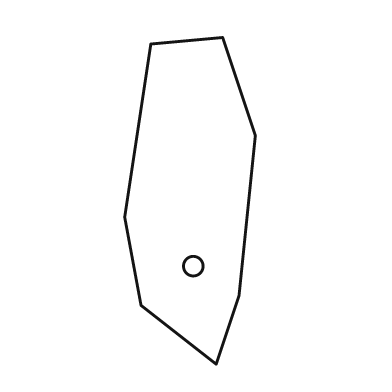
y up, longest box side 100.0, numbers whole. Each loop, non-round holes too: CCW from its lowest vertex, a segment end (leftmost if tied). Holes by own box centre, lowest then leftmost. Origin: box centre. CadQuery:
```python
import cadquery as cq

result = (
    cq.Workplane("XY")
    .moveTo(8.0, -50.0)
    .lineTo(15.0, -29.0)
    .lineTo(20.0, 20.0)
    .lineTo(10.0, 50.0)
    .lineTo(-12.0, 48.0)
    .lineTo(-20.0, -5.0)
    .lineTo(-15.0, -32.0)
    .close()
    .moveTo(1.0, -20.0)
    .circle(3.0)
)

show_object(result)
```